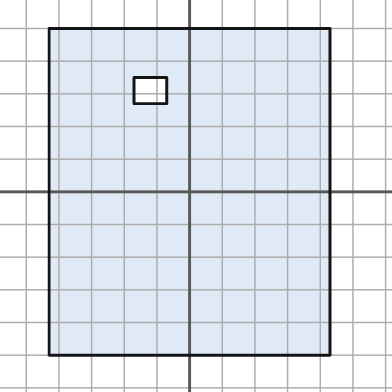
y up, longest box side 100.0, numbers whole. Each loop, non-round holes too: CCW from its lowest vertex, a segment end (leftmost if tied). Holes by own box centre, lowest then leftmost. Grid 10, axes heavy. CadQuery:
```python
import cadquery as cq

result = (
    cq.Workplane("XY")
    .moveTo(-43.0, -50.0)
    .lineTo(43.0, -50.0)
    .lineTo(43.0, 50.0)
    .lineTo(-43.0, 50.0)
    .close()
    .moveTo(-17.0, 27.0)
    .lineTo(-7.0, 27.0)
    .lineTo(-7.0, 35.0)
    .lineTo(-17.0, 35.0)
    .close()
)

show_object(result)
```